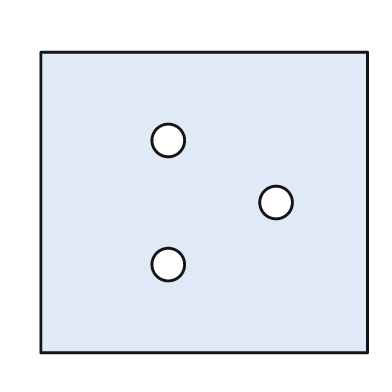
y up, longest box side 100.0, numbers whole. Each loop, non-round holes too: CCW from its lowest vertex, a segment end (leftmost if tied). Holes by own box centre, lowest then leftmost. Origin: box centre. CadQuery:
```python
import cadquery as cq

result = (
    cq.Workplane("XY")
    .moveTo(-50.0, -46.0)
    .lineTo(50.0, -46.0)
    .lineTo(50.0, 46.0)
    .lineTo(-50.0, 46.0)
    .close()
    .moveTo(-11.0, -19.0)
    .circle(5.0)
    .moveTo(22.0, 0.0)
    .circle(5.0)
    .moveTo(-11.0, 19.0)
    .circle(5.0)
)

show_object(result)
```